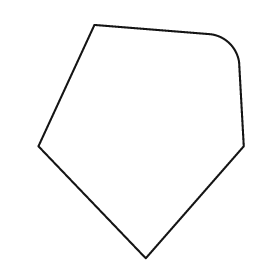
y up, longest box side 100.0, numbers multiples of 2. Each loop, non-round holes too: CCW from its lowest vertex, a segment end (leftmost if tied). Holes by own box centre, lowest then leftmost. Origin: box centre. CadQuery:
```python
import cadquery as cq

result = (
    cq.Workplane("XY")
    .moveTo(2.0, -50.0)
    .lineTo(44.0, -2.0)
    .lineTo(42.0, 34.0)
    .threePointArc((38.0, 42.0), (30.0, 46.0))
    .lineTo(-20.0, 50.0)
    .lineTo(-44.0, -2.0)
    .close()
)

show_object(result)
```